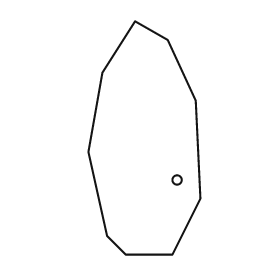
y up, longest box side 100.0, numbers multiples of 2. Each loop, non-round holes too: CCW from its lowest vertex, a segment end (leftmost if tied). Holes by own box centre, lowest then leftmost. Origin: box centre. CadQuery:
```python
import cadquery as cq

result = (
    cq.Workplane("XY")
    .moveTo(-8.0, -50.0)
    .lineTo(12.0, -50.0)
    .lineTo(24.0, -26.0)
    .lineTo(22.0, 16.0)
    .lineTo(10.0, 42.0)
    .lineTo(-4.0, 50.0)
    .lineTo(-18.0, 28.0)
    .lineTo(-24.0, -6.0)
    .lineTo(-16.0, -42.0)
    .close()
    .moveTo(14.0, -18.0)
    .circle(2.0)
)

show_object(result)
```